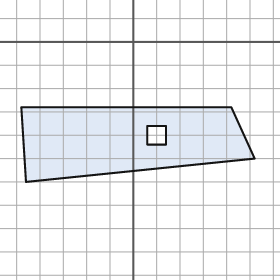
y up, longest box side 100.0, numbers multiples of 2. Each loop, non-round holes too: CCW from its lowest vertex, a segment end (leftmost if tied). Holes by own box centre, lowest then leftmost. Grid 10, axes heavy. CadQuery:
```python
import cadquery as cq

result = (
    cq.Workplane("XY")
    .moveTo(-46.0, -60.0)
    .lineTo(52.0, -50.0)
    .lineTo(42.0, -28.0)
    .lineTo(-48.0, -28.0)
    .close()
    .moveTo(6.0, -44.0)
    .lineTo(14.0, -44.0)
    .lineTo(14.0, -36.0)
    .lineTo(6.0, -36.0)
    .close()
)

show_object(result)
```